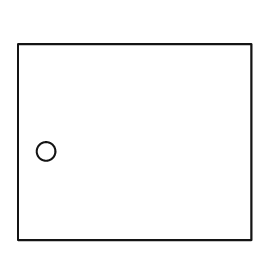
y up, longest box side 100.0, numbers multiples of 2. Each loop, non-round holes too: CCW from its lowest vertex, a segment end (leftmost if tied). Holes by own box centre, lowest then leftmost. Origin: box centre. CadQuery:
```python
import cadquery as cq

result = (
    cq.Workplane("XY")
    .moveTo(-50.0, -42.0)
    .lineTo(50.0, -42.0)
    .lineTo(50.0, 42.0)
    .lineTo(-50.0, 42.0)
    .close()
    .moveTo(-38.0, -4.0)
    .circle(4.0)
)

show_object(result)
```